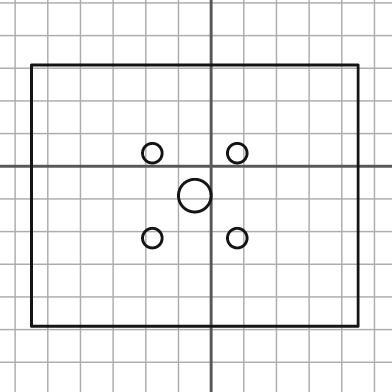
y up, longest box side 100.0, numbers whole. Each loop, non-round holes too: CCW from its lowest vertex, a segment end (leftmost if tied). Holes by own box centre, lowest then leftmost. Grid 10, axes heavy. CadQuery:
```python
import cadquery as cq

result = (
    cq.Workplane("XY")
    .moveTo(-55.0, -49.0)
    .lineTo(45.0, -49.0)
    .lineTo(45.0, 31.0)
    .lineTo(-55.0, 31.0)
    .close()
    .moveTo(-18.0, -22.0)
    .circle(3.0)
    .moveTo(8.0, -22.0)
    .circle(3.0)
    .moveTo(-5.0, -9.0)
    .circle(5.0)
    .moveTo(-18.0, 4.0)
    .circle(3.0)
    .moveTo(8.0, 4.0)
    .circle(3.0)
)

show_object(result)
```